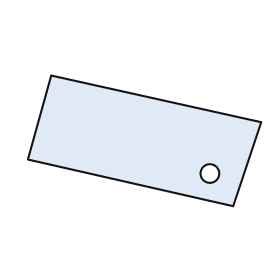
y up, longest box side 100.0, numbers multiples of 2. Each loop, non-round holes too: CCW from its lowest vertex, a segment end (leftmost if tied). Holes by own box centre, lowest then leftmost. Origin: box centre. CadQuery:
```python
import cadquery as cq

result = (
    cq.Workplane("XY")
    .moveTo(38.0, -28.0)
    .lineTo(50.0, 8.0)
    .lineTo(-40.0, 28.0)
    .lineTo(-50.0, -8.0)
    .close()
    .moveTo(28.0, -14.0)
    .circle(4.0)
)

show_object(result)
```